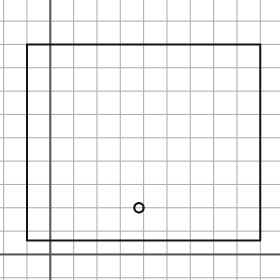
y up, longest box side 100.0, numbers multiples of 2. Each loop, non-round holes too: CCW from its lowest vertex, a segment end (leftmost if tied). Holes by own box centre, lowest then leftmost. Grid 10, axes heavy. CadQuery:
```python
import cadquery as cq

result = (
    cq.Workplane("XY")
    .moveTo(-10.0, 6.0)
    .lineTo(90.0, 6.0)
    .lineTo(90.0, 90.0)
    .lineTo(-10.0, 90.0)
    .close()
    .moveTo(38.0, 20.0)
    .circle(2.0)
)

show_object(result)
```